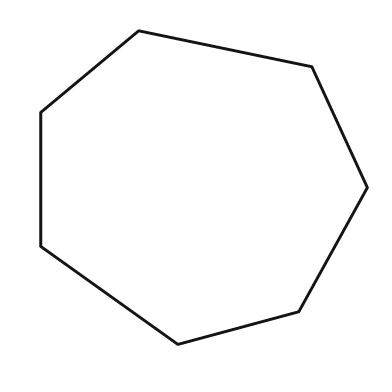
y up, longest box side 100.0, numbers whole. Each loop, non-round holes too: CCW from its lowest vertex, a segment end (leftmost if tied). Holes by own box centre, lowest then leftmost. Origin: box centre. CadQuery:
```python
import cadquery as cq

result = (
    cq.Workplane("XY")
    .moveTo(-8.0, -48.0)
    .lineTo(29.0, -38.0)
    .lineTo(50.0, 0.0)
    .lineTo(33.0, 37.0)
    .lineTo(-20.0, 48.0)
    .lineTo(-50.0, 23.0)
    .lineTo(-50.0, -18.0)
    .close()
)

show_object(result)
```